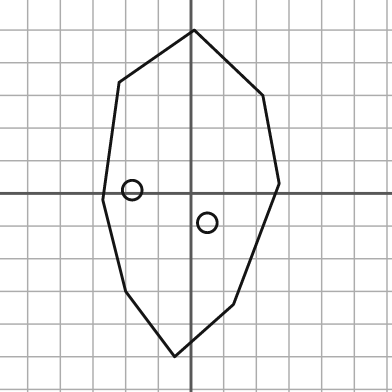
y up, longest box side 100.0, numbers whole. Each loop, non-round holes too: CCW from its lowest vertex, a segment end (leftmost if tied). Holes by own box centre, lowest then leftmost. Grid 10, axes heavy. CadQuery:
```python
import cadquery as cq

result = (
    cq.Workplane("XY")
    .moveTo(-5.0, -50.0)
    .lineTo(13.0, -34.0)
    .lineTo(27.0, 3.0)
    .lineTo(22.0, 30.0)
    .lineTo(1.0, 50.0)
    .lineTo(-22.0, 34.0)
    .lineTo(-27.0, -2.0)
    .lineTo(-20.0, -30.0)
    .close()
    .moveTo(5.0, -9.0)
    .circle(3.0)
    .moveTo(-18.0, 1.0)
    .circle(3.0)
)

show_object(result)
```